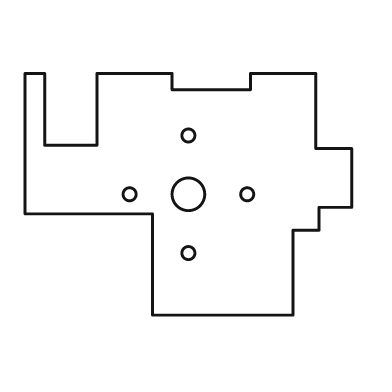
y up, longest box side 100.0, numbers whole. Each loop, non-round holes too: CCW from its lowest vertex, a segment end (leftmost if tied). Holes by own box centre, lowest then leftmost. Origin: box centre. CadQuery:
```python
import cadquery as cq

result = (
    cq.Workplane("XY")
    .moveTo(-11.0, -37.0)
    .lineTo(32.0, -37.0)
    .lineTo(32.0, -11.0)
    .lineTo(40.0, -11.0)
    .lineTo(40.0, -4.0)
    .lineTo(50.0, -4.0)
    .lineTo(50.0, 14.0)
    .lineTo(39.0, 14.0)
    .lineTo(39.0, 37.0)
    .lineTo(19.0, 37.0)
    .lineTo(19.0, 32.0)
    .lineTo(-5.0, 32.0)
    .lineTo(-5.0, 37.0)
    .lineTo(-28.0, 37.0)
    .lineTo(-28.0, 15.0)
    .lineTo(-44.0, 15.0)
    .lineTo(-44.0, 37.0)
    .lineTo(-50.0, 37.0)
    .lineTo(-50.0, -6.0)
    .lineTo(-11.0, -6.0)
    .close()
    .moveTo(0.0, -18.0)
    .circle(2.0)
    .moveTo(-18.0, 0.0)
    .circle(2.0)
    .moveTo(0.0, 0.0)
    .circle(5.0)
    .moveTo(18.0, 0.0)
    .circle(2.0)
    .moveTo(0.0, 18.0)
    .circle(2.0)
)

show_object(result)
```